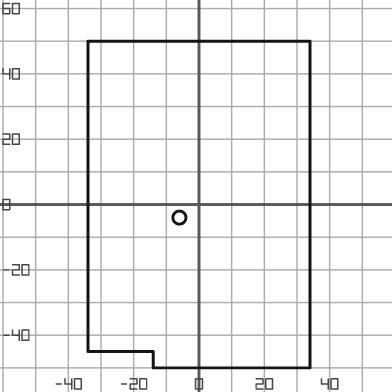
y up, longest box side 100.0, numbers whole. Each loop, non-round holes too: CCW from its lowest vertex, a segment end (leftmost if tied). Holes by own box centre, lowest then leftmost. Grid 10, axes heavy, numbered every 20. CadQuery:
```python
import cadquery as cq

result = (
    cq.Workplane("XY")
    .moveTo(-14.0, -50.0)
    .lineTo(34.0, -50.0)
    .lineTo(34.0, 50.0)
    .lineTo(-34.0, 50.0)
    .lineTo(-34.0, -45.0)
    .lineTo(-14.0, -45.0)
    .close()
    .moveTo(-6.0, -4.0)
    .circle(2.0)
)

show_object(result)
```